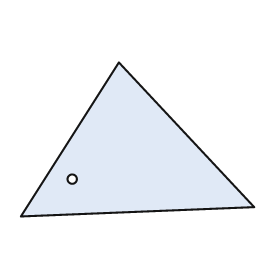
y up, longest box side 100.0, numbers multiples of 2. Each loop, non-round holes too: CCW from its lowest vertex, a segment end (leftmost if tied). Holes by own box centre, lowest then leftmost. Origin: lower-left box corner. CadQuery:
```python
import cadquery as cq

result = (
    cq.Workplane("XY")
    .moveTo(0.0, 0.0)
    .lineTo(100.0, 4.0)
    .lineTo(42.0, 66.0)
    .close()
    .moveTo(22.0, 16.0)
    .circle(2.0)
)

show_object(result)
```